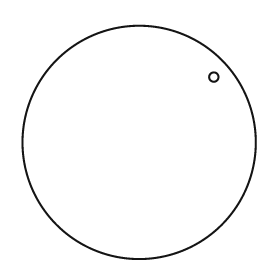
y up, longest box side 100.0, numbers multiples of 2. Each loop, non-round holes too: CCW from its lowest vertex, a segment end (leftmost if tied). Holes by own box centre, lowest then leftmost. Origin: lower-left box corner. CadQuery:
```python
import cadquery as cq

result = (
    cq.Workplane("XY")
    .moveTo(50.0, 50.0)
    .circle(50.0)
    .moveTo(82.0, 78.0)
    .circle(2.0)
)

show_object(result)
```